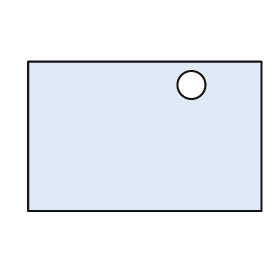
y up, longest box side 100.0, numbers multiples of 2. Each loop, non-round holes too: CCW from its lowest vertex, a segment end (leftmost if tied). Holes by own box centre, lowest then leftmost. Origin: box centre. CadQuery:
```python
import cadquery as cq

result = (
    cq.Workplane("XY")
    .moveTo(-50.0, -32.0)
    .lineTo(50.0, -32.0)
    .lineTo(50.0, 32.0)
    .lineTo(-50.0, 32.0)
    .close()
    .moveTo(20.0, 22.0)
    .circle(6.0)
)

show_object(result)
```